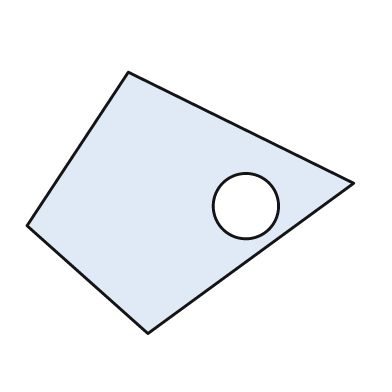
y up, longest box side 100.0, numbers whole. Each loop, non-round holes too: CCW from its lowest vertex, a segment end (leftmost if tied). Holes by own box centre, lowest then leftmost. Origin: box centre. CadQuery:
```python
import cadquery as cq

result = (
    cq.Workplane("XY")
    .moveTo(-13.0, -40.0)
    .lineTo(50.0, 6.0)
    .lineTo(-19.0, 40.0)
    .lineTo(-50.0, -7.0)
    .close()
    .moveTo(17.0, -1.0)
    .circle(10.0)
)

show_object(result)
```